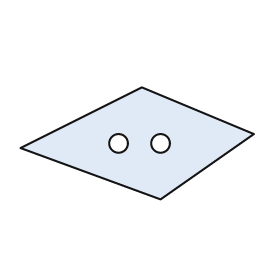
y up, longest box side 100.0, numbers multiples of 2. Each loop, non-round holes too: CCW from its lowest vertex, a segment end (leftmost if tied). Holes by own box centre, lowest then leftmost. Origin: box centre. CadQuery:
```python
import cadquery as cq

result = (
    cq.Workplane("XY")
    .moveTo(10.0, -24.0)
    .lineTo(50.0, 4.0)
    .lineTo(2.0, 24.0)
    .lineTo(-50.0, -2.0)
    .close()
    .moveTo(-8.0, 0.0)
    .circle(4.0)
    .moveTo(10.0, 0.0)
    .circle(4.0)
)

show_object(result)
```